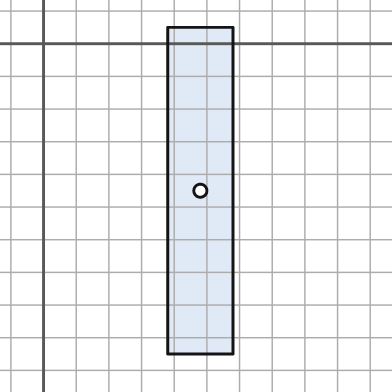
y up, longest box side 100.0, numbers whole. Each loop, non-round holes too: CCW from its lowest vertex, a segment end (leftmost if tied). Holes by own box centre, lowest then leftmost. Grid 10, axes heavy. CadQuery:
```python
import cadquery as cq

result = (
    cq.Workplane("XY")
    .moveTo(38.0, -95.0)
    .lineTo(58.0, -95.0)
    .lineTo(58.0, 5.0)
    .lineTo(38.0, 5.0)
    .close()
    .moveTo(48.0, -45.0)
    .circle(2.0)
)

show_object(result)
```